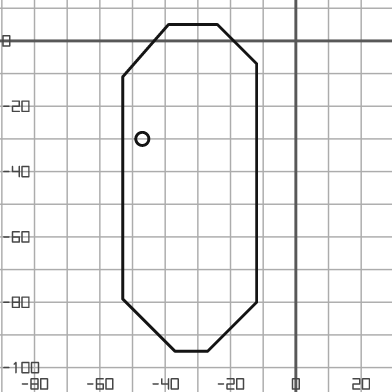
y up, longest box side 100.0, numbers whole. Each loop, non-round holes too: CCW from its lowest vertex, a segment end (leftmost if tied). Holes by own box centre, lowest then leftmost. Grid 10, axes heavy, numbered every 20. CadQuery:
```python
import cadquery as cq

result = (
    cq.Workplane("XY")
    .moveTo(-37.0, -95.0)
    .lineTo(-27.0, -95.0)
    .lineTo(-12.0, -80.0)
    .lineTo(-12.0, -7.0)
    .lineTo(-24.0, 5.0)
    .lineTo(-39.0, 5.0)
    .lineTo(-53.0, -11.0)
    .lineTo(-53.0, -79.0)
    .close()
    .moveTo(-47.0, -30.0)
    .circle(2.0)
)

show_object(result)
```